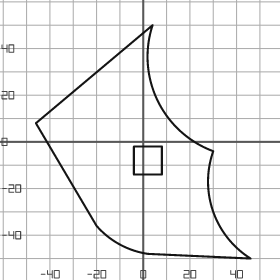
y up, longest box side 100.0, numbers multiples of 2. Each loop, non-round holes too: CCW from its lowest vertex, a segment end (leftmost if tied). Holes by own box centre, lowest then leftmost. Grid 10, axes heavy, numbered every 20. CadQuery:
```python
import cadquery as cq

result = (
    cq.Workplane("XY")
    .moveTo(46.0, -50.0)
    .threePointArc((30.0, -30.0), (30.0, -4.0))
    .threePointArc((6.0, 18.0), (4.0, 50.0))
    .lineTo(-46.0, 8.0)
    .lineTo(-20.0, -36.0)
    .threePointArc((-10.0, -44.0), (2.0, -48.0))
    .close()
    .moveTo(-4.0, -14.0)
    .lineTo(8.0, -14.0)
    .lineTo(8.0, -2.0)
    .lineTo(-4.0, -2.0)
    .close()
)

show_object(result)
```